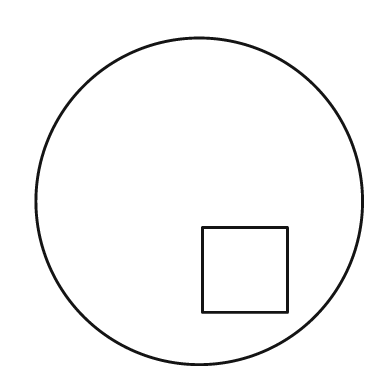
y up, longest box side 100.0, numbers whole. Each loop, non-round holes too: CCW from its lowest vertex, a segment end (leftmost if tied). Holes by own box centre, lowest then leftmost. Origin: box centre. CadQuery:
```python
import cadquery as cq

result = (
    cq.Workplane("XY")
    .moveTo(0.0, 0.0)
    .circle(50.0)
    .moveTo(1.0, -34.0)
    .lineTo(27.0, -34.0)
    .lineTo(27.0, -8.0)
    .lineTo(1.0, -8.0)
    .close()
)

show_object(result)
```